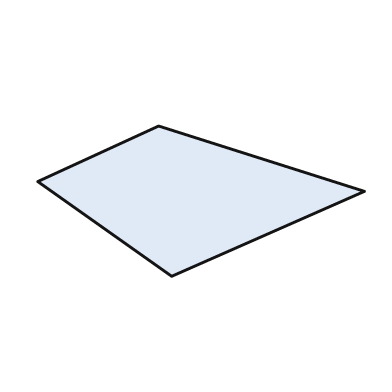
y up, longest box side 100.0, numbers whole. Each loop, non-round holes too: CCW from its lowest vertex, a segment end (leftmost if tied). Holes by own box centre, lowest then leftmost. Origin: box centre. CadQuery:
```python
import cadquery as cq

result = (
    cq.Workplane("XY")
    .moveTo(-9.0, -23.0)
    .lineTo(50.0, 3.0)
    .lineTo(-13.0, 23.0)
    .lineTo(-50.0, 6.0)
    .close()
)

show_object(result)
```